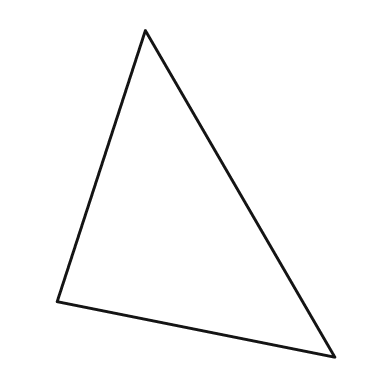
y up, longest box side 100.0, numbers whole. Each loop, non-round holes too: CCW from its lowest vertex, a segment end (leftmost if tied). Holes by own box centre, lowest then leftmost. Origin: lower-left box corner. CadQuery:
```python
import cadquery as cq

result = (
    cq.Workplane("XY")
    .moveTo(85.0, 0.0)
    .lineTo(27.0, 100.0)
    .lineTo(0.0, 17.0)
    .close()
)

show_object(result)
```